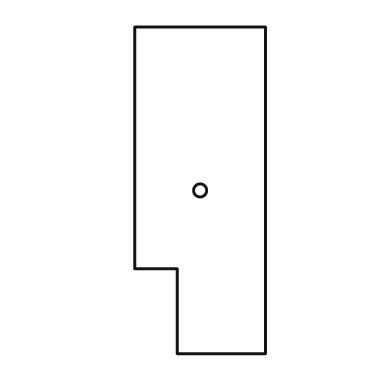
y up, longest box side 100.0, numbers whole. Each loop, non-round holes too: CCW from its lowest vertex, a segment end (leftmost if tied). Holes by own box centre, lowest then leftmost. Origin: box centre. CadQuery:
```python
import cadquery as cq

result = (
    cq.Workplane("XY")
    .moveTo(-7.0, -50.0)
    .lineTo(20.0, -50.0)
    .lineTo(20.0, 50.0)
    .lineTo(-20.0, 50.0)
    .lineTo(-20.0, -24.0)
    .lineTo(-7.0, -24.0)
    .close()
    .moveTo(0.0, 0.0)
    .circle(2.0)
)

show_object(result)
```